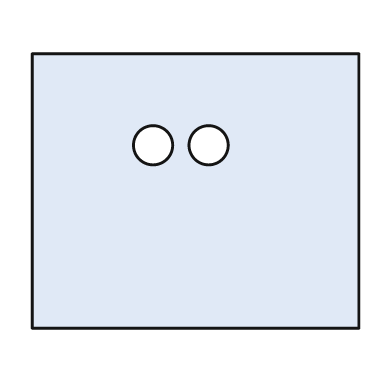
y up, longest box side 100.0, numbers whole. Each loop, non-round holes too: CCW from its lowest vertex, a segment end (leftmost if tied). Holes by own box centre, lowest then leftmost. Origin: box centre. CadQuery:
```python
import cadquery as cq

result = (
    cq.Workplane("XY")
    .moveTo(-50.0, -42.0)
    .lineTo(50.0, -42.0)
    .lineTo(50.0, 42.0)
    .lineTo(-50.0, 42.0)
    .close()
    .moveTo(-13.0, 14.0)
    .circle(6.0)
    .moveTo(4.0, 14.0)
    .circle(6.0)
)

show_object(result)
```